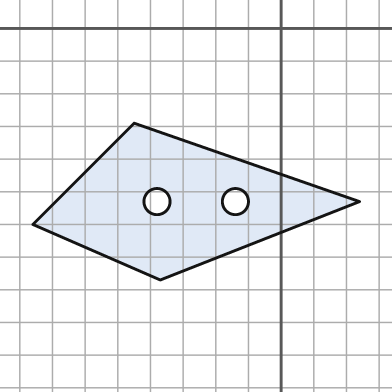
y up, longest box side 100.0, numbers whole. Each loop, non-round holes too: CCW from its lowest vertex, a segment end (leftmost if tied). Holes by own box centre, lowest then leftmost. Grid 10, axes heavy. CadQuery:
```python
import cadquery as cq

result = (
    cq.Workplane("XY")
    .moveTo(-37.0, -77.0)
    .lineTo(24.0, -53.0)
    .lineTo(-45.0, -29.0)
    .lineTo(-76.0, -60.0)
    .close()
    .moveTo(-38.0, -53.0)
    .circle(4.0)
    .moveTo(-14.0, -53.0)
    .circle(4.0)
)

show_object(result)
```